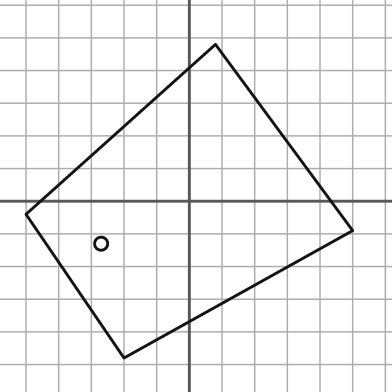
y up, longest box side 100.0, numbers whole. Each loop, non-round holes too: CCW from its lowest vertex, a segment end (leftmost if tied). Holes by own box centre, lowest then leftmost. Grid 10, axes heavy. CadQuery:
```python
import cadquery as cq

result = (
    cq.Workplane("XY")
    .moveTo(-20.0, -48.0)
    .lineTo(50.0, -9.0)
    .lineTo(8.0, 48.0)
    .lineTo(-50.0, -4.0)
    .close()
    .moveTo(-27.0, -13.0)
    .circle(2.0)
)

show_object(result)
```